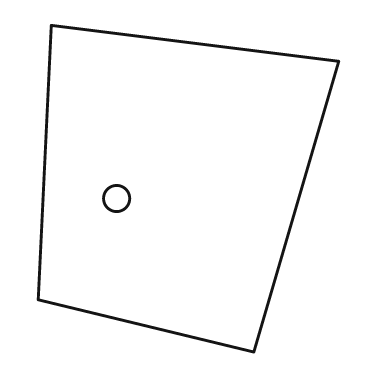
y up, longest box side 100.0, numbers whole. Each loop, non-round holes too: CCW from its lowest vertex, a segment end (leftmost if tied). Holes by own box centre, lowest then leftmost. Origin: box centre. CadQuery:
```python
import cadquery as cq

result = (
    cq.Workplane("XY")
    .moveTo(20.0, -50.0)
    .lineTo(46.0, 39.0)
    .lineTo(-42.0, 50.0)
    .lineTo(-46.0, -34.0)
    .close()
    .moveTo(-22.0, -3.0)
    .circle(4.0)
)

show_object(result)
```